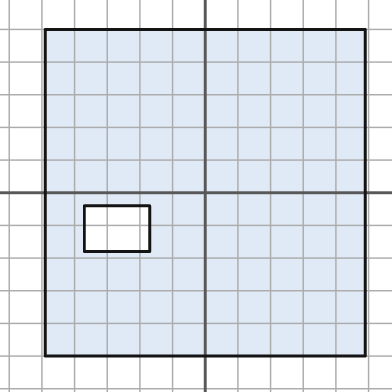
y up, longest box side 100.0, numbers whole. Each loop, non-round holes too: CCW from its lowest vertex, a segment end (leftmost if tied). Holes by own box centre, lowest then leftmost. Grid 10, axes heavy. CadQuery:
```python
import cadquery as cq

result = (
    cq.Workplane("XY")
    .moveTo(-49.0, -50.0)
    .lineTo(49.0, -50.0)
    .lineTo(49.0, 50.0)
    .lineTo(-49.0, 50.0)
    .close()
    .moveTo(-37.0, -18.0)
    .lineTo(-17.0, -18.0)
    .lineTo(-17.0, -4.0)
    .lineTo(-37.0, -4.0)
    .close()
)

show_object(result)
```